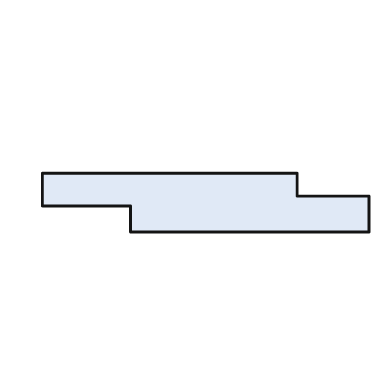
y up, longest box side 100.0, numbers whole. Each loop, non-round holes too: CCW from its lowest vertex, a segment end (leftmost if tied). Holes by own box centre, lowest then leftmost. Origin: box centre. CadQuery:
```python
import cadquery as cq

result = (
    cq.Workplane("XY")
    .moveTo(-23.0, -9.0)
    .lineTo(50.0, -9.0)
    .lineTo(50.0, 2.0)
    .lineTo(28.0, 2.0)
    .lineTo(28.0, 9.0)
    .lineTo(-50.0, 9.0)
    .lineTo(-50.0, -1.0)
    .lineTo(-23.0, -1.0)
    .close()
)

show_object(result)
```